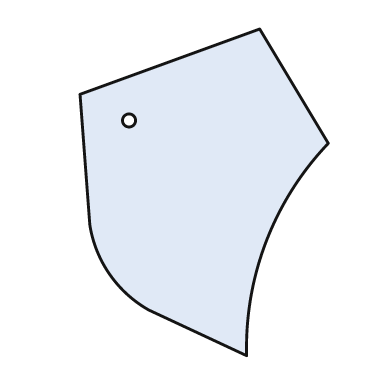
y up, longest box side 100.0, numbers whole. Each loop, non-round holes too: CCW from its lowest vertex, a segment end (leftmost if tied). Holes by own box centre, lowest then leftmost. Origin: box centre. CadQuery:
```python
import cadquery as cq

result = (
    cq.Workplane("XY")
    .moveTo(13.0, -50.0)
    .threePointArc((19.0, -15.0), (38.0, 15.0))
    .lineTo(17.0, 50.0)
    .lineTo(-38.0, 30.0)
    .lineTo(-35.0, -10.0)
    .threePointArc((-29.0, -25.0), (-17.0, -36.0))
    .close()
    .moveTo(-23.0, 22.0)
    .circle(2.0)
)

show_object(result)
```